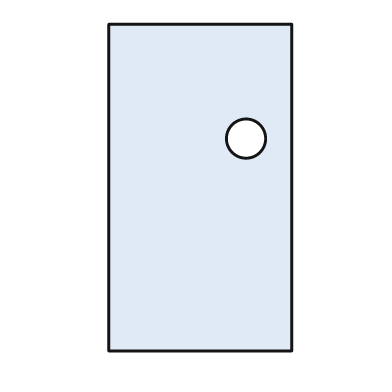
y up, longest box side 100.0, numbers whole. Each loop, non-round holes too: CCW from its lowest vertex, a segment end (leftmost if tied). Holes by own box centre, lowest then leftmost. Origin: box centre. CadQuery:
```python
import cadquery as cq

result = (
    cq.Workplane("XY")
    .moveTo(-28.0, -50.0)
    .lineTo(28.0, -50.0)
    .lineTo(28.0, 50.0)
    .lineTo(-28.0, 50.0)
    .close()
    .moveTo(14.0, 15.0)
    .circle(6.0)
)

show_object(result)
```